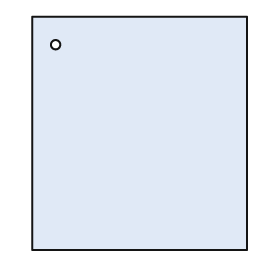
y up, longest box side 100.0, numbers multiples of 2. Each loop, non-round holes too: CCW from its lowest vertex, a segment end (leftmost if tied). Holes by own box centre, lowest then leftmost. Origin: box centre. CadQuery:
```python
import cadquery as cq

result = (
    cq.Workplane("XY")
    .moveTo(-46.0, -50.0)
    .lineTo(46.0, -50.0)
    .lineTo(46.0, 50.0)
    .lineTo(-46.0, 50.0)
    .close()
    .moveTo(-36.0, 38.0)
    .circle(2.0)
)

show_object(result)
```